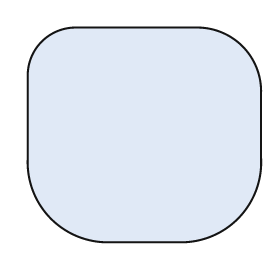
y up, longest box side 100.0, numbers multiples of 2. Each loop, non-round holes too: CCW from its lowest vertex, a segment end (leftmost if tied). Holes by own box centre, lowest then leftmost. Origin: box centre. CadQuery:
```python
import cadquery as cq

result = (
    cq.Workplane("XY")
    .moveTo(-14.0, -46.0)
    .lineTo(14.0, -46.0)
    .threePointArc((40.0, -36.0), (50.0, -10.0))
    .lineTo(50.0, 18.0)
    .threePointArc((42.0, 38.0), (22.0, 46.0))
    .lineTo(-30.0, 46.0)
    .threePointArc((-44.0, 40.0), (-50.0, 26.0))
    .lineTo(-50.0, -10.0)
    .threePointArc((-40.0, -36.0), (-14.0, -46.0))
    .close()
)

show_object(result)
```